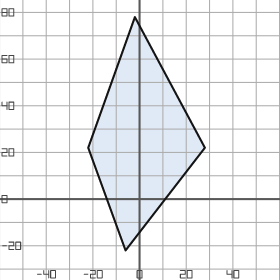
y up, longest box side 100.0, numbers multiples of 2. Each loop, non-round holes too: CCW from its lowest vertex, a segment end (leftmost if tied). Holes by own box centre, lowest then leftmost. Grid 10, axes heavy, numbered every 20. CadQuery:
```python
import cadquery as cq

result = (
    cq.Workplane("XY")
    .moveTo(-6.0, -22.0)
    .lineTo(28.0, 22.0)
    .lineTo(-2.0, 78.0)
    .lineTo(-22.0, 22.0)
    .close()
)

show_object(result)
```